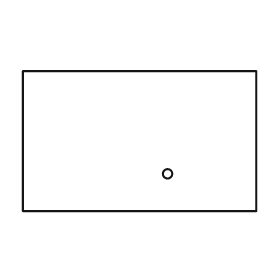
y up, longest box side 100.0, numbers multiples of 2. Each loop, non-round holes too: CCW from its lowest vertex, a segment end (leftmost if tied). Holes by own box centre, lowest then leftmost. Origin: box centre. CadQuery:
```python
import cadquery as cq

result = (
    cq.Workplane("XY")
    .moveTo(-50.0, -30.0)
    .lineTo(50.0, -30.0)
    .lineTo(50.0, 30.0)
    .lineTo(-50.0, 30.0)
    .close()
    .moveTo(12.0, -14.0)
    .circle(2.0)
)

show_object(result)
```